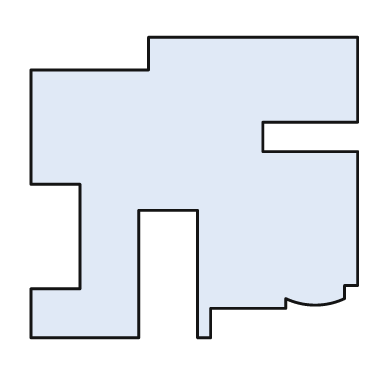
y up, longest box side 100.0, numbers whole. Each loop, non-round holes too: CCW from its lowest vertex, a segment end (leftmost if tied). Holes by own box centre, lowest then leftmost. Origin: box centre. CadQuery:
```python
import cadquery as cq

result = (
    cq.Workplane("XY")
    .moveTo(-50.0, -46.0)
    .lineTo(-17.0, -46.0)
    .lineTo(-17.0, -7.0)
    .lineTo(1.0, -7.0)
    .lineTo(1.0, -46.0)
    .lineTo(5.0, -46.0)
    .lineTo(5.0, -37.0)
    .lineTo(28.0, -37.0)
    .lineTo(28.0, -34.0)
    .threePointArc((37.0, -36.0), (46.0, -34.0))
    .lineTo(46.0, -30.0)
    .lineTo(50.0, -30.0)
    .lineTo(50.0, 11.0)
    .lineTo(21.0, 11.0)
    .lineTo(21.0, 20.0)
    .lineTo(50.0, 20.0)
    .lineTo(50.0, 46.0)
    .lineTo(-14.0, 46.0)
    .lineTo(-14.0, 36.0)
    .lineTo(-50.0, 36.0)
    .lineTo(-50.0, 1.0)
    .lineTo(-35.0, 1.0)
    .lineTo(-35.0, -31.0)
    .lineTo(-50.0, -31.0)
    .close()
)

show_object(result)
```